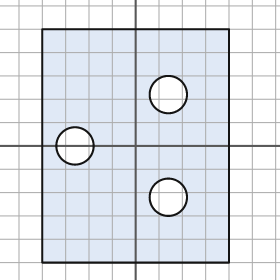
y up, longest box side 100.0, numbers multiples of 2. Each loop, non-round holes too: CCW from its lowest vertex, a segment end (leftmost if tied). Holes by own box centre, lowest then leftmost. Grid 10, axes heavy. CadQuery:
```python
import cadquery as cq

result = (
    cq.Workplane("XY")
    .moveTo(-40.0, -50.0)
    .lineTo(40.0, -50.0)
    .lineTo(40.0, 50.0)
    .lineTo(-40.0, 50.0)
    .close()
    .moveTo(14.0, -22.0)
    .circle(8.0)
    .moveTo(-26.0, 0.0)
    .circle(8.0)
    .moveTo(14.0, 22.0)
    .circle(8.0)
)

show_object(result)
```